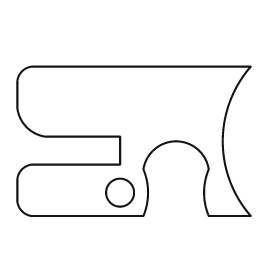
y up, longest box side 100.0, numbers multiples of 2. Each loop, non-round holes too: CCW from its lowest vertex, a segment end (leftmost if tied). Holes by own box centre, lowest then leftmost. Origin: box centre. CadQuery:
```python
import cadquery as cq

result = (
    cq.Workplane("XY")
    .moveTo(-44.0, -32.0)
    .lineTo(4.0, -32.0)
    .threePointArc((6.0, -22.0), (4.0, -12.0))
    .threePointArc((18.0, 0.0), (32.0, -12.0))
    .threePointArc((30.0, -22.0), (32.0, -32.0))
    .lineTo(50.0, -32.0)
    .threePointArc((38.0, 0.0), (50.0, 32.0))
    .lineTo(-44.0, 32.0)
    .threePointArc((-48.0, 30.0), (-50.0, 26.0))
    .lineTo(-50.0, 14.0)
    .threePointArc((-46.0, 6.0), (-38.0, 2.0))
    .lineTo(-6.0, 2.0)
    .lineTo(-6.0, -10.0)
    .lineTo(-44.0, -10.0)
    .threePointArc((-48.0, -12.0), (-50.0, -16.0))
    .lineTo(-50.0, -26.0)
    .threePointArc((-48.0, -30.0), (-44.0, -32.0))
    .close()
    .moveTo(-6.0, -22.0)
    .circle(6.0)
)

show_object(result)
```